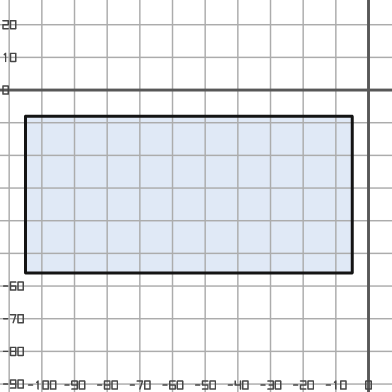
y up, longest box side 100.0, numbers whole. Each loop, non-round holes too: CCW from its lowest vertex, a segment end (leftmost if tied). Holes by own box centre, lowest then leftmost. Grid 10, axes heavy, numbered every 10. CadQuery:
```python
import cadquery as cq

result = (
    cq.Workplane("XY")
    .moveTo(-105.0, -56.0)
    .lineTo(-5.0, -56.0)
    .lineTo(-5.0, -8.0)
    .lineTo(-105.0, -8.0)
    .close()
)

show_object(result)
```